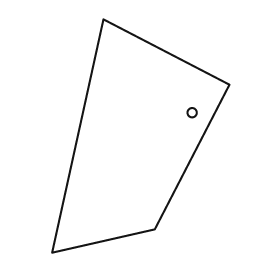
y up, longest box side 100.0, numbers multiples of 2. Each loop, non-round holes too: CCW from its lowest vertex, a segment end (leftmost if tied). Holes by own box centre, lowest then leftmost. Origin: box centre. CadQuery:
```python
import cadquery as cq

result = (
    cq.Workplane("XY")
    .moveTo(-38.0, -50.0)
    .lineTo(6.0, -40.0)
    .lineTo(38.0, 22.0)
    .lineTo(-16.0, 50.0)
    .close()
    .moveTo(22.0, 10.0)
    .circle(2.0)
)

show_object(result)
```